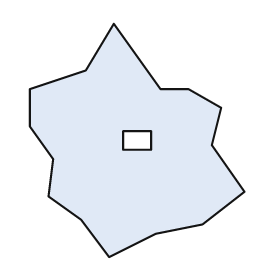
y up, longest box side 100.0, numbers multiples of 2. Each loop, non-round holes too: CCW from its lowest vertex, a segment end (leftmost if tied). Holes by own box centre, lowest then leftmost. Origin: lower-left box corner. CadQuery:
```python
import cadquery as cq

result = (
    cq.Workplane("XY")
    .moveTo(34.0, 0.0)
    .lineTo(54.0, 10.0)
    .lineTo(74.0, 14.0)
    .lineTo(92.0, 28.0)
    .lineTo(78.0, 48.0)
    .lineTo(82.0, 64.0)
    .lineTo(68.0, 72.0)
    .lineTo(56.0, 72.0)
    .lineTo(36.0, 100.0)
    .lineTo(24.0, 80.0)
    .lineTo(0.0, 72.0)
    .lineTo(0.0, 56.0)
    .lineTo(10.0, 42.0)
    .lineTo(8.0, 26.0)
    .lineTo(22.0, 16.0)
    .close()
    .moveTo(40.0, 46.0)
    .lineTo(52.0, 46.0)
    .lineTo(52.0, 54.0)
    .lineTo(40.0, 54.0)
    .close()
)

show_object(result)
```